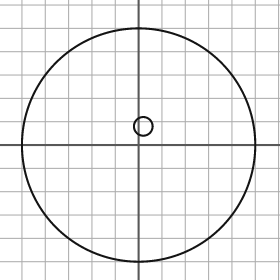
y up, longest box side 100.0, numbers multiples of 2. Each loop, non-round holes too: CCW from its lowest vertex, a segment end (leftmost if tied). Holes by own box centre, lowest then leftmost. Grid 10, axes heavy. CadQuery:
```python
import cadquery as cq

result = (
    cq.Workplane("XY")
    .moveTo(0.0, 0.0)
    .circle(50.0)
    .moveTo(2.0, 8.0)
    .circle(4.0)
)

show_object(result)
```